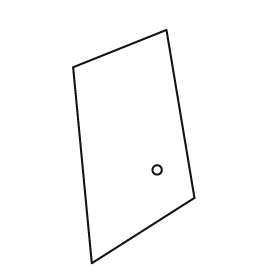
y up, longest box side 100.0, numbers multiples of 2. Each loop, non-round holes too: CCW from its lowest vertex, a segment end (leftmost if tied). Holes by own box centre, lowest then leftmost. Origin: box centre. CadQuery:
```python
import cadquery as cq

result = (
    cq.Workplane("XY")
    .moveTo(-18.0, -50.0)
    .lineTo(26.0, -22.0)
    .lineTo(14.0, 50.0)
    .lineTo(-26.0, 34.0)
    .close()
    .moveTo(10.0, -10.0)
    .circle(2.0)
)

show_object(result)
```